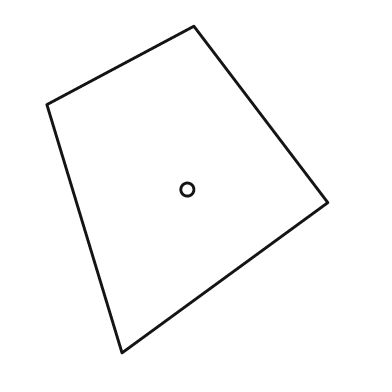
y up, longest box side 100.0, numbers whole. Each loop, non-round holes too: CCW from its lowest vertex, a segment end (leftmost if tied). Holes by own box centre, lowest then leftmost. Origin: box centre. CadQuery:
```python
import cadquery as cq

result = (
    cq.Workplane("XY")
    .moveTo(-20.0, -50.0)
    .lineTo(43.0, -4.0)
    .lineTo(2.0, 50.0)
    .lineTo(-43.0, 26.0)
    .close()
    .moveTo(0.0, 0.0)
    .circle(2.0)
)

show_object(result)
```